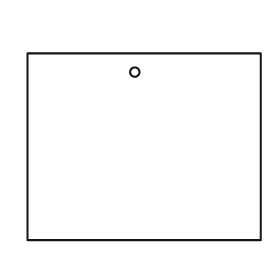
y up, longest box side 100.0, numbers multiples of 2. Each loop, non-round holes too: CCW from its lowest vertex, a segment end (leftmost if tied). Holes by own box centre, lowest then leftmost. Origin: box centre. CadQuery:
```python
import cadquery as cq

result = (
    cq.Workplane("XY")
    .moveTo(-50.0, -40.0)
    .lineTo(50.0, -40.0)
    .lineTo(50.0, 40.0)
    .lineTo(-50.0, 40.0)
    .close()
    .moveTo(-4.0, 32.0)
    .circle(2.0)
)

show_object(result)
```